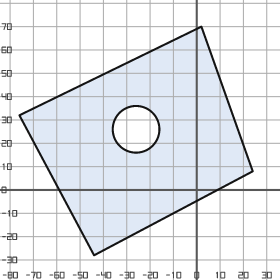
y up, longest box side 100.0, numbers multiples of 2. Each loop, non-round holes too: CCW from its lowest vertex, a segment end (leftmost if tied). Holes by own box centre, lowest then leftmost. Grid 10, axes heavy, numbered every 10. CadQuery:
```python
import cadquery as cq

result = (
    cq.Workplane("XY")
    .moveTo(-44.0, -28.0)
    .lineTo(24.0, 8.0)
    .lineTo(2.0, 70.0)
    .lineTo(-76.0, 32.0)
    .close()
    .moveTo(-26.0, 26.0)
    .circle(10.0)
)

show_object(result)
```